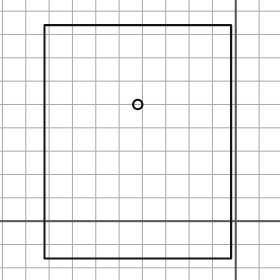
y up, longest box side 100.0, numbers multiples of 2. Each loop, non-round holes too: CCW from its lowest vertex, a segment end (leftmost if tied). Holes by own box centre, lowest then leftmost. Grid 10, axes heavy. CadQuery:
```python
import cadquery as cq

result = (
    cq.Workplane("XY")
    .moveTo(-82.0, -16.0)
    .lineTo(-2.0, -16.0)
    .lineTo(-2.0, 84.0)
    .lineTo(-82.0, 84.0)
    .close()
    .moveTo(-42.0, 50.0)
    .circle(2.0)
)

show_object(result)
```